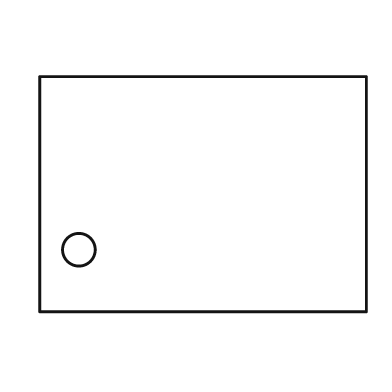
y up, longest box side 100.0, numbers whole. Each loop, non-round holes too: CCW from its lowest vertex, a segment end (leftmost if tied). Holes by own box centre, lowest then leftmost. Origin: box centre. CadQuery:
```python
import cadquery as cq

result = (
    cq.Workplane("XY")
    .moveTo(-50.0, -36.0)
    .lineTo(50.0, -36.0)
    .lineTo(50.0, 36.0)
    .lineTo(-50.0, 36.0)
    .close()
    .moveTo(-38.0, -17.0)
    .circle(5.0)
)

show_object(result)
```